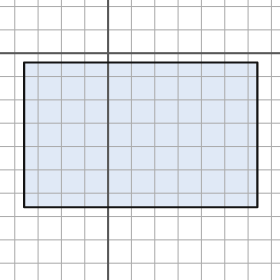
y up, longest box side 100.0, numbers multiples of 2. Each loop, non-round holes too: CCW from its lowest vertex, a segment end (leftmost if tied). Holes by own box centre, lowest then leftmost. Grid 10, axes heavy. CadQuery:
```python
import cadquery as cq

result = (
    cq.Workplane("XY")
    .moveTo(-36.0, -66.0)
    .lineTo(64.0, -66.0)
    .lineTo(64.0, -4.0)
    .lineTo(-36.0, -4.0)
    .close()
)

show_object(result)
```